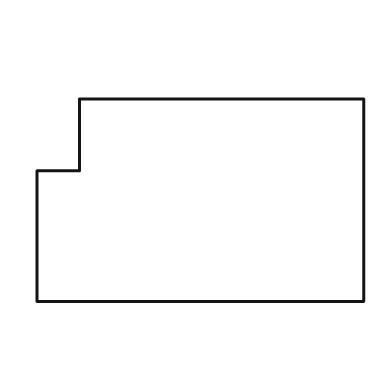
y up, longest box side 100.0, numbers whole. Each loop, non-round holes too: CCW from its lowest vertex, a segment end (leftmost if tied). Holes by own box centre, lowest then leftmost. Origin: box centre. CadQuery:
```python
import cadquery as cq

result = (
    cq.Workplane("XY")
    .moveTo(-50.0, -31.0)
    .lineTo(50.0, -31.0)
    .lineTo(50.0, 31.0)
    .lineTo(-37.0, 31.0)
    .lineTo(-37.0, 9.0)
    .lineTo(-50.0, 9.0)
    .close()
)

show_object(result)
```